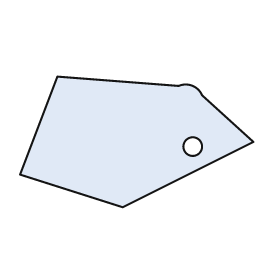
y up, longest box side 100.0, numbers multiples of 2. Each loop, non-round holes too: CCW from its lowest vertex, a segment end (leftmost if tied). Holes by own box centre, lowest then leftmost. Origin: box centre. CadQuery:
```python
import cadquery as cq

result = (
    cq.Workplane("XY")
    .moveTo(-6.0, -28.0)
    .lineTo(50.0, 0.0)
    .lineTo(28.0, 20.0)
    .threePointArc((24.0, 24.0), (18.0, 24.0))
    .lineTo(-34.0, 28.0)
    .lineTo(-50.0, -14.0)
    .close()
    .moveTo(24.0, -2.0)
    .circle(4.0)
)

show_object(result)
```